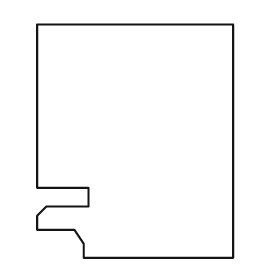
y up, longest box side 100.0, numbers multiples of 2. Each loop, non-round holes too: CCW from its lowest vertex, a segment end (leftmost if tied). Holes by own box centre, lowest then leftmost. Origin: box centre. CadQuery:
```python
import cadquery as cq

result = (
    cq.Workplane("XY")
    .moveTo(-22.0, -50.0)
    .lineTo(42.0, -50.0)
    .lineTo(42.0, 50.0)
    .lineTo(-42.0, 50.0)
    .lineTo(-42.0, -20.0)
    .lineTo(-20.0, -20.0)
    .lineTo(-20.0, -28.0)
    .lineTo(-38.0, -28.0)
    .lineTo(-42.0, -32.0)
    .lineTo(-42.0, -38.0)
    .lineTo(-26.0, -38.0)
    .lineTo(-22.0, -44.0)
    .close()
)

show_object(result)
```